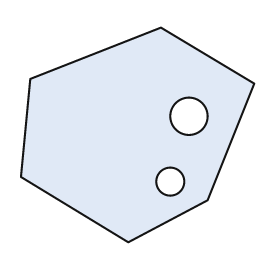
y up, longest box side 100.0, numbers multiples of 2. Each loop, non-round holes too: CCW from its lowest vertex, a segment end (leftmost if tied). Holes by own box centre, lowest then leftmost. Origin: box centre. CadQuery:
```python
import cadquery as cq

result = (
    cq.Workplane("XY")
    .moveTo(-4.0, -46.0)
    .lineTo(30.0, -28.0)
    .lineTo(50.0, 22.0)
    .lineTo(10.0, 46.0)
    .lineTo(-46.0, 24.0)
    .lineTo(-50.0, -18.0)
    .close()
    .moveTo(14.0, -20.0)
    .circle(6.0)
    .moveTo(22.0, 8.0)
    .circle(8.0)
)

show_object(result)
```